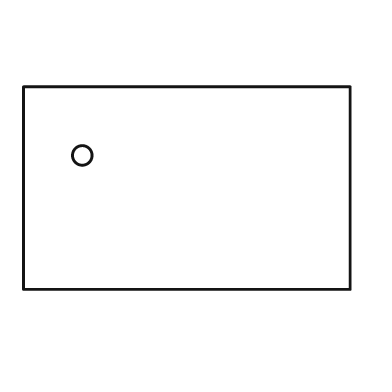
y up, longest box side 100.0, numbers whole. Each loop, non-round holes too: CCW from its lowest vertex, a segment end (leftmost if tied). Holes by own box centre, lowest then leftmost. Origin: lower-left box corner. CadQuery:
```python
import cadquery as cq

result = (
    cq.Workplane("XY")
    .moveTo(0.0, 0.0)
    .lineTo(100.0, 0.0)
    .lineTo(100.0, 62.0)
    .lineTo(0.0, 62.0)
    .close()
    .moveTo(18.0, 41.0)
    .circle(3.0)
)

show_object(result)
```